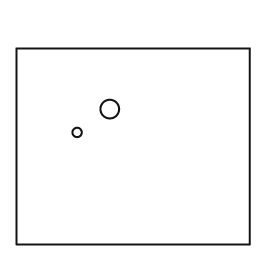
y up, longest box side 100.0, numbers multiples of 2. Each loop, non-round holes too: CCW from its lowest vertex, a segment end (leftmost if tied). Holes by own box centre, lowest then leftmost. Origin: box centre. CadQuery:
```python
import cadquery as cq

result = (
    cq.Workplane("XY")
    .moveTo(-50.0, -42.0)
    .lineTo(50.0, -42.0)
    .lineTo(50.0, 42.0)
    .lineTo(-50.0, 42.0)
    .close()
    .moveTo(-24.0, 6.0)
    .circle(2.0)
    .moveTo(-10.0, 16.0)
    .circle(4.0)
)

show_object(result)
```